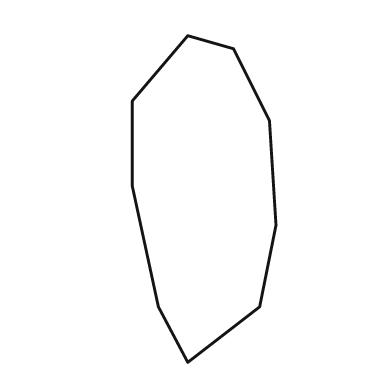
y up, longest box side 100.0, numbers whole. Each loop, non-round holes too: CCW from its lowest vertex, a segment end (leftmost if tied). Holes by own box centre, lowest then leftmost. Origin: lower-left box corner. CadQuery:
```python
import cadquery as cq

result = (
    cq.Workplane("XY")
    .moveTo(17.0, 0.0)
    .lineTo(39.0, 17.0)
    .lineTo(44.0, 42.0)
    .lineTo(42.0, 74.0)
    .lineTo(31.0, 96.0)
    .lineTo(17.0, 100.0)
    .lineTo(0.0, 80.0)
    .lineTo(0.0, 54.0)
    .lineTo(8.0, 17.0)
    .close()
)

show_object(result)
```